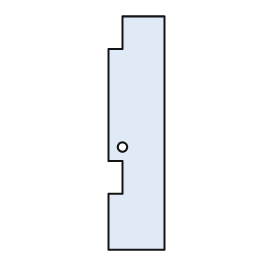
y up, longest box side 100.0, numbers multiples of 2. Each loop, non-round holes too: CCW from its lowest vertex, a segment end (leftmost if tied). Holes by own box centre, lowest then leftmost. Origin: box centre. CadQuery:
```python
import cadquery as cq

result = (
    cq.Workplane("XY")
    .moveTo(-12.0, -50.0)
    .lineTo(12.0, -50.0)
    .lineTo(12.0, 50.0)
    .lineTo(-6.0, 50.0)
    .lineTo(-6.0, 36.0)
    .lineTo(-12.0, 36.0)
    .lineTo(-12.0, -12.0)
    .lineTo(-6.0, -12.0)
    .lineTo(-6.0, -26.0)
    .lineTo(-12.0, -26.0)
    .close()
    .moveTo(-6.0, -6.0)
    .circle(2.0)
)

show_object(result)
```